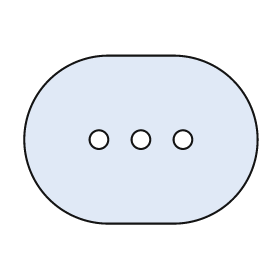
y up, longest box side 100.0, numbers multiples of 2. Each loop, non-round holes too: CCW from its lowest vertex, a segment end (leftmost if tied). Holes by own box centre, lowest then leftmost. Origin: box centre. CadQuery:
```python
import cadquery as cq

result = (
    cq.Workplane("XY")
    .moveTo(-14.0, -36.0)
    .lineTo(14.0, -36.0)
    .threePointArc((50.0, 0.0), (14.0, 36.0))
    .lineTo(-14.0, 36.0)
    .threePointArc((-50.0, 0.0), (-14.0, -36.0))
    .close()
    .moveTo(-18.0, 0.0)
    .circle(4.0)
    .moveTo(0.0, 0.0)
    .circle(4.0)
    .moveTo(18.0, 0.0)
    .circle(4.0)
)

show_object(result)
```